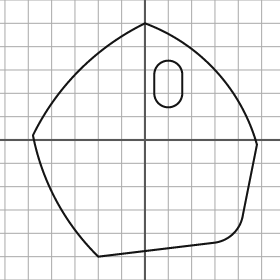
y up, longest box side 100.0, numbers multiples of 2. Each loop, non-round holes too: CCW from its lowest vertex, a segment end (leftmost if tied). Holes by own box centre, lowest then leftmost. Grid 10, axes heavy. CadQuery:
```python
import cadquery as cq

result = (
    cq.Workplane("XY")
    .moveTo(-20.0, -50.0)
    .lineTo(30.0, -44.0)
    .threePointArc((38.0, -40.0), (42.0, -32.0))
    .lineTo(48.0, -2.0)
    .threePointArc((30.0, 30.0), (0.0, 50.0))
    .threePointArc((-28.0, 30.0), (-48.0, 2.0))
    .threePointArc((-38.0, -26.0), (-20.0, -50.0))
    .close()
    .moveTo(4.0, 20.0)
    .threePointArc((10.0, 14.0), (16.0, 20.0))
    .lineTo(16.0, 28.0)
    .threePointArc((10.0, 34.0), (4.0, 28.0))
    .close()
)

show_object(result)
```